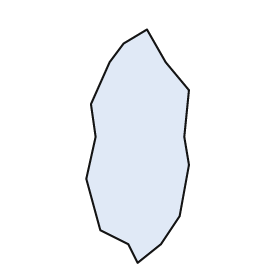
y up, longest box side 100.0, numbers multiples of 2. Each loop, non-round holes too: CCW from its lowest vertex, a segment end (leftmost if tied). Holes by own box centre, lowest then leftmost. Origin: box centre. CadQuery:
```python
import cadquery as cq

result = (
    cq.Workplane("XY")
    .moveTo(0.0, -50.0)
    .lineTo(10.0, -42.0)
    .lineTo(18.0, -30.0)
    .lineTo(22.0, -8.0)
    .lineTo(20.0, 4.0)
    .lineTo(22.0, 24.0)
    .lineTo(12.0, 36.0)
    .lineTo(4.0, 50.0)
    .lineTo(-6.0, 44.0)
    .lineTo(-12.0, 36.0)
    .lineTo(-20.0, 18.0)
    .lineTo(-18.0, 4.0)
    .lineTo(-22.0, -14.0)
    .lineTo(-16.0, -36.0)
    .lineTo(-4.0, -42.0)
    .close()
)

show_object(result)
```